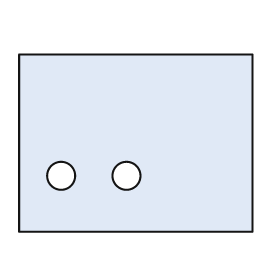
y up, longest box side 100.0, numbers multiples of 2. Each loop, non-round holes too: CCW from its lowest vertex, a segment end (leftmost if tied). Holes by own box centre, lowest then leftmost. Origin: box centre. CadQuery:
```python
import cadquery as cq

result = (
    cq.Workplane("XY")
    .moveTo(-50.0, -38.0)
    .lineTo(50.0, -38.0)
    .lineTo(50.0, 38.0)
    .lineTo(-50.0, 38.0)
    .close()
    .moveTo(-32.0, -14.0)
    .circle(6.0)
    .moveTo(-4.0, -14.0)
    .circle(6.0)
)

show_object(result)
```